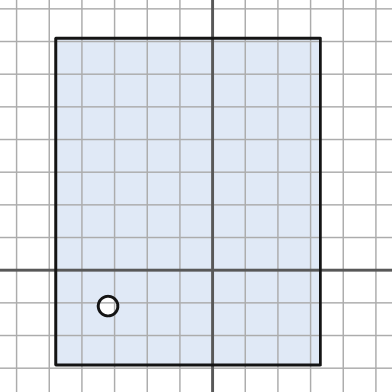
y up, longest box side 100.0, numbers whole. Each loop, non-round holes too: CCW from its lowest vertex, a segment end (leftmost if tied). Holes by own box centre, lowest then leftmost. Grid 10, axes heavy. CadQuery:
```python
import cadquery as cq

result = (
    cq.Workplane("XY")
    .moveTo(-48.0, -29.0)
    .lineTo(33.0, -29.0)
    .lineTo(33.0, 71.0)
    .lineTo(-48.0, 71.0)
    .close()
    .moveTo(-32.0, -11.0)
    .circle(3.0)
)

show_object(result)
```